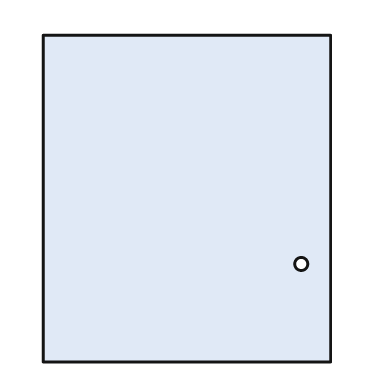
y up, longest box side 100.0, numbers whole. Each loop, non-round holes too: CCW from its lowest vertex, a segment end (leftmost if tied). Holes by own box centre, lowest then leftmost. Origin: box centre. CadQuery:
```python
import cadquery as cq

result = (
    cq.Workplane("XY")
    .moveTo(-44.0, -50.0)
    .lineTo(44.0, -50.0)
    .lineTo(44.0, 50.0)
    .lineTo(-44.0, 50.0)
    .close()
    .moveTo(35.0, -20.0)
    .circle(2.0)
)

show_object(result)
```